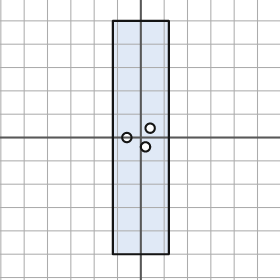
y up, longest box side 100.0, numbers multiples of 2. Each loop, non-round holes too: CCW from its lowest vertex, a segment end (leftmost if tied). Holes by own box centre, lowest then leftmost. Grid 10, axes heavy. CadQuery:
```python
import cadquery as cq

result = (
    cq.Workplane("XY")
    .moveTo(-12.0, -50.0)
    .lineTo(12.0, -50.0)
    .lineTo(12.0, 50.0)
    .lineTo(-12.0, 50.0)
    .close()
    .moveTo(2.0, -4.0)
    .circle(2.0)
    .moveTo(-6.0, 0.0)
    .circle(2.0)
    .moveTo(4.0, 4.0)
    .circle(2.0)
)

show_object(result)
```